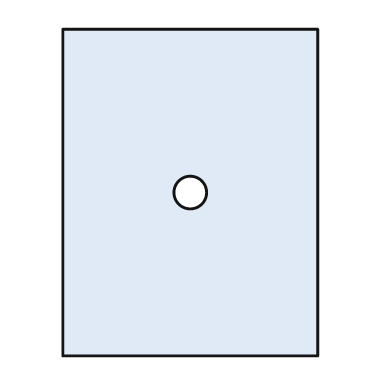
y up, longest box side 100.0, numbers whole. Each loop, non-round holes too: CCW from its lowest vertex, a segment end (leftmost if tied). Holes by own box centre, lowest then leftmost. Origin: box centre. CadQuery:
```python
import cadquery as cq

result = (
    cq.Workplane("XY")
    .moveTo(-39.0, -50.0)
    .lineTo(39.0, -50.0)
    .lineTo(39.0, 50.0)
    .lineTo(-39.0, 50.0)
    .close()
    .moveTo(0.0, 0.0)
    .circle(5.0)
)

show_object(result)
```